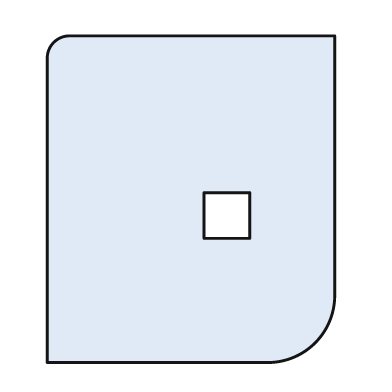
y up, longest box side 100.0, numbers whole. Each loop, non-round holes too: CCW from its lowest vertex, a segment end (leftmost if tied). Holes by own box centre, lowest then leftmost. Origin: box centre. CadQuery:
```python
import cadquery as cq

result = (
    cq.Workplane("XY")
    .moveTo(-44.0, -50.0)
    .lineTo(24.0, -50.0)
    .threePointArc((38.0, -44.0), (44.0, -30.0))
    .lineTo(44.0, 50.0)
    .lineTo(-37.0, 50.0)
    .threePointArc((-42.0, 48.0), (-44.0, 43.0))
    .close()
    .moveTo(4.0, -12.0)
    .lineTo(18.0, -12.0)
    .lineTo(18.0, 2.0)
    .lineTo(4.0, 2.0)
    .close()
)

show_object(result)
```